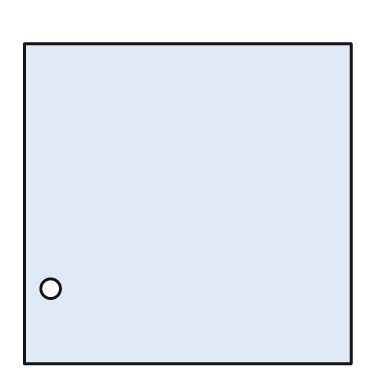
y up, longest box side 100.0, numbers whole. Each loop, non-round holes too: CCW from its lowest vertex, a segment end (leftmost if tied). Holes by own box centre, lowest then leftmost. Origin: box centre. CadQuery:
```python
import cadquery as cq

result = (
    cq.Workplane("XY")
    .moveTo(-50.0, -49.0)
    .lineTo(50.0, -49.0)
    .lineTo(50.0, 49.0)
    .lineTo(-50.0, 49.0)
    .close()
    .moveTo(-42.0, -26.0)
    .circle(3.0)
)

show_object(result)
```